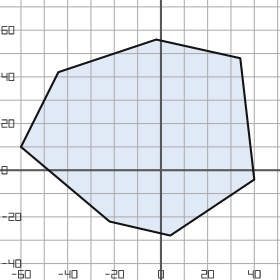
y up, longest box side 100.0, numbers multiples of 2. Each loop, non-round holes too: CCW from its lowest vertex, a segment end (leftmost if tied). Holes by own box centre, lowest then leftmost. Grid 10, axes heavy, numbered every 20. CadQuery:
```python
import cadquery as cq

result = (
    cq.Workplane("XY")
    .moveTo(4.0, -28.0)
    .lineTo(40.0, -4.0)
    .lineTo(34.0, 48.0)
    .lineTo(-2.0, 56.0)
    .lineTo(-44.0, 42.0)
    .lineTo(-60.0, 10.0)
    .lineTo(-22.0, -22.0)
    .close()
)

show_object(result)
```